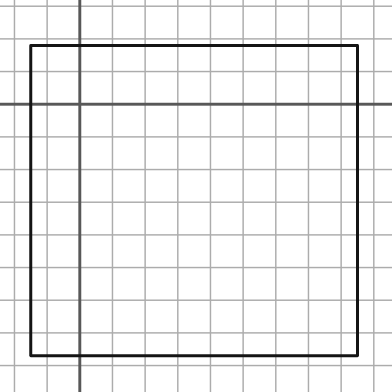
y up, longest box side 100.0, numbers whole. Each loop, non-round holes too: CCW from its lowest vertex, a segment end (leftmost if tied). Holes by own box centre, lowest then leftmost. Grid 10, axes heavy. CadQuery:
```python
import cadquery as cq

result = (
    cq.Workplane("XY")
    .moveTo(-15.0, -77.0)
    .lineTo(85.0, -77.0)
    .lineTo(85.0, 18.0)
    .lineTo(-15.0, 18.0)
    .close()
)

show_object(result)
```